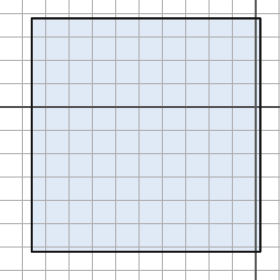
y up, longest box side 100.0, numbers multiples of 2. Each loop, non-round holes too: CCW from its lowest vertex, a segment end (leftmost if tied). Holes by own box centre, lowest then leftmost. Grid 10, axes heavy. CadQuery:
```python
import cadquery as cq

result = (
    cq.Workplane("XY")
    .moveTo(-96.0, -62.0)
    .lineTo(2.0, -62.0)
    .lineTo(2.0, 38.0)
    .lineTo(-96.0, 38.0)
    .close()
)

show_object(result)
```